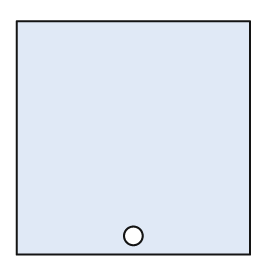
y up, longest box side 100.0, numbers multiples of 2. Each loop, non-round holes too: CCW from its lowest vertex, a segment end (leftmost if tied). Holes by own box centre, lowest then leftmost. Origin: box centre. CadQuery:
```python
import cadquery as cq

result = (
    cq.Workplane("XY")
    .moveTo(-50.0, -50.0)
    .lineTo(50.0, -50.0)
    .lineTo(50.0, 50.0)
    .lineTo(-50.0, 50.0)
    .close()
    .moveTo(0.0, -42.0)
    .circle(4.0)
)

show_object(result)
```